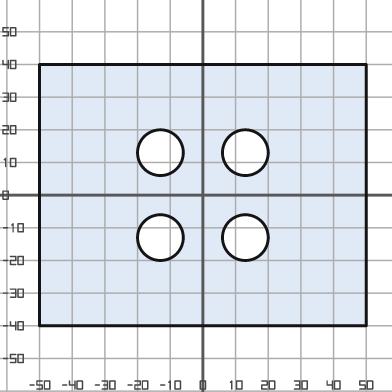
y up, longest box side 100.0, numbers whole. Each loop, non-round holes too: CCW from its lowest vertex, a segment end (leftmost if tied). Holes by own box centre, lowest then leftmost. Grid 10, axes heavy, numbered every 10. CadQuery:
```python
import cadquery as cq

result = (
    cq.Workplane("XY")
    .moveTo(-50.0, -40.0)
    .lineTo(50.0, -40.0)
    .lineTo(50.0, 40.0)
    .lineTo(-50.0, 40.0)
    .close()
    .moveTo(-13.0, -13.0)
    .circle(7.0)
    .moveTo(13.0, -13.0)
    .circle(7.0)
    .moveTo(-13.0, 13.0)
    .circle(7.0)
    .moveTo(13.0, 13.0)
    .circle(7.0)
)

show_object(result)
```